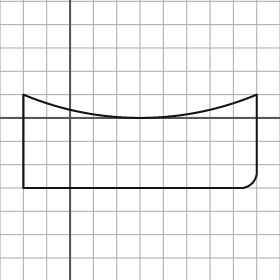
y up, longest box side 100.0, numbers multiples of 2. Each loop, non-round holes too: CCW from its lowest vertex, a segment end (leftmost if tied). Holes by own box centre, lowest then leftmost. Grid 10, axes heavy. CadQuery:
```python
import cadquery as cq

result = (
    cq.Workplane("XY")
    .moveTo(-20.0, -30.0)
    .lineTo(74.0, -30.0)
    .threePointArc((78.0, -28.0), (80.0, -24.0))
    .lineTo(80.0, 10.0)
    .threePointArc((30.0, 0.0), (-20.0, 10.0))
    .close()
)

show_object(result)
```